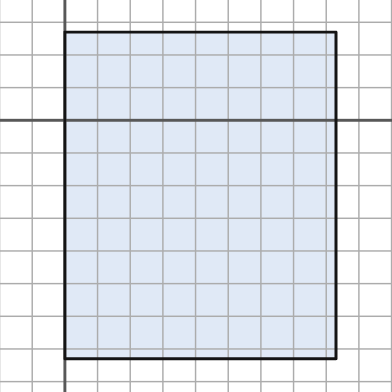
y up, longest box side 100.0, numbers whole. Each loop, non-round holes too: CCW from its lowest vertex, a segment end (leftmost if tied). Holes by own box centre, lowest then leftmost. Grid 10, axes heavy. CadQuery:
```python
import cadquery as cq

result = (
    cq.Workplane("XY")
    .moveTo(0.0, -73.0)
    .lineTo(83.0, -73.0)
    .lineTo(83.0, 27.0)
    .lineTo(0.0, 27.0)
    .close()
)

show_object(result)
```